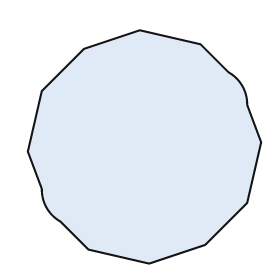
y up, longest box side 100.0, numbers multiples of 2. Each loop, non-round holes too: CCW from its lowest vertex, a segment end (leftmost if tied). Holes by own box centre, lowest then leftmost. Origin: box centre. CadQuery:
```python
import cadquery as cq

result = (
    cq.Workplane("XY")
    .moveTo(2.0, -50.0)
    .lineTo(26.0, -42.0)
    .lineTo(44.0, -24.0)
    .lineTo(50.0, 2.0)
    .lineTo(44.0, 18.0)
    .threePointArc((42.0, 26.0), (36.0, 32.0))
    .lineTo(24.0, 44.0)
    .lineTo(-2.0, 50.0)
    .lineTo(-26.0, 42.0)
    .lineTo(-44.0, 24.0)
    .lineTo(-50.0, -2.0)
    .lineTo(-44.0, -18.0)
    .threePointArc((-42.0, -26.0), (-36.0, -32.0))
    .lineTo(-24.0, -44.0)
    .close()
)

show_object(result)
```